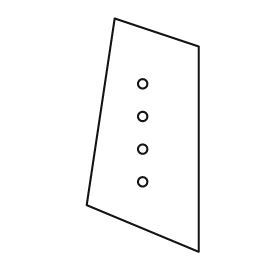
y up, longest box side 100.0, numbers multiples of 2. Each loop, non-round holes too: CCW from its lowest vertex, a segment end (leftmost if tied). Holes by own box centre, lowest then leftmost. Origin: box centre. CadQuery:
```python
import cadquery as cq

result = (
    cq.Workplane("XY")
    .moveTo(24.0, -50.0)
    .lineTo(24.0, 38.0)
    .lineTo(-12.0, 50.0)
    .lineTo(-24.0, -30.0)
    .close()
    .moveTo(0.0, -20.0)
    .circle(2.0)
    .moveTo(0.0, -6.0)
    .circle(2.0)
    .moveTo(0.0, 8.0)
    .circle(2.0)
    .moveTo(0.0, 22.0)
    .circle(2.0)
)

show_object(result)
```